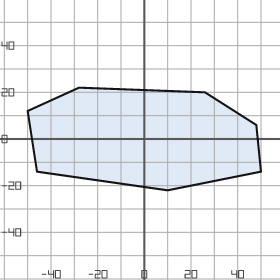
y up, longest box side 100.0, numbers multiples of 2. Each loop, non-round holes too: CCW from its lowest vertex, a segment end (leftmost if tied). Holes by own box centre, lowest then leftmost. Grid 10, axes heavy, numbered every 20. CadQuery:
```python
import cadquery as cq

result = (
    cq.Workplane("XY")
    .moveTo(10.0, -22.0)
    .lineTo(50.0, -14.0)
    .lineTo(48.0, 6.0)
    .lineTo(26.0, 20.0)
    .lineTo(-28.0, 22.0)
    .lineTo(-50.0, 12.0)
    .lineTo(-46.0, -14.0)
    .close()
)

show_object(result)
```